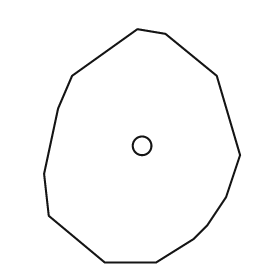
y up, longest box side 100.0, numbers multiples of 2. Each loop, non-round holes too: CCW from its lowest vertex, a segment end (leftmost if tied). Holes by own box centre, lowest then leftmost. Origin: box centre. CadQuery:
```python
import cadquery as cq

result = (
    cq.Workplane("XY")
    .moveTo(-16.0, -50.0)
    .lineTo(6.0, -50.0)
    .lineTo(22.0, -40.0)
    .lineTo(28.0, -34.0)
    .lineTo(36.0, -22.0)
    .lineTo(42.0, -4.0)
    .lineTo(32.0, 30.0)
    .lineTo(10.0, 48.0)
    .lineTo(-2.0, 50.0)
    .lineTo(-30.0, 30.0)
    .lineTo(-36.0, 16.0)
    .lineTo(-42.0, -12.0)
    .lineTo(-40.0, -30.0)
    .close()
    .moveTo(0.0, 0.0)
    .circle(4.0)
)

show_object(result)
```